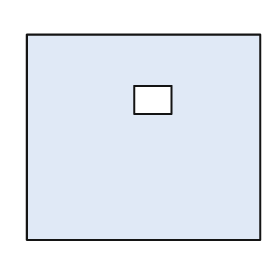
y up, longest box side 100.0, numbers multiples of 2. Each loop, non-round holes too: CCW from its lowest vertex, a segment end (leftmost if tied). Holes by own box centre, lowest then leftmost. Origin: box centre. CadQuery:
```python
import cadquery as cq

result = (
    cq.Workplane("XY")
    .moveTo(-50.0, -44.0)
    .lineTo(50.0, -44.0)
    .lineTo(50.0, 44.0)
    .lineTo(-50.0, 44.0)
    .close()
    .moveTo(-4.0, 10.0)
    .lineTo(12.0, 10.0)
    .lineTo(12.0, 22.0)
    .lineTo(-4.0, 22.0)
    .close()
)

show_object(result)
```